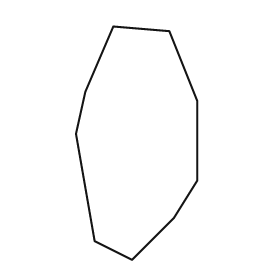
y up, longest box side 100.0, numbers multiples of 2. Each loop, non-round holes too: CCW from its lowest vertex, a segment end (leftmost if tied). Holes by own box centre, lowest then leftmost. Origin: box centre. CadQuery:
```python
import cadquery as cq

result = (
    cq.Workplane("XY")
    .moveTo(-2.0, -50.0)
    .lineTo(16.0, -32.0)
    .lineTo(26.0, -16.0)
    .lineTo(26.0, 18.0)
    .lineTo(14.0, 48.0)
    .lineTo(-10.0, 50.0)
    .lineTo(-22.0, 22.0)
    .lineTo(-26.0, 4.0)
    .lineTo(-18.0, -42.0)
    .close()
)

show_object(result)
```